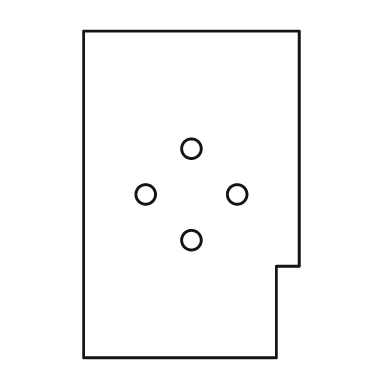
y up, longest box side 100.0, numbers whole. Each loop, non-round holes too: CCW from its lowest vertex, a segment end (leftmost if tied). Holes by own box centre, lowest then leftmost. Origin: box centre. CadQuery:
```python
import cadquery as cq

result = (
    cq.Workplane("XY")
    .moveTo(-33.0, -50.0)
    .lineTo(26.0, -50.0)
    .lineTo(26.0, -22.0)
    .lineTo(33.0, -22.0)
    .lineTo(33.0, 50.0)
    .lineTo(-33.0, 50.0)
    .close()
    .moveTo(0.0, -14.0)
    .circle(3.0)
    .moveTo(-14.0, 0.0)
    .circle(3.0)
    .moveTo(14.0, 0.0)
    .circle(3.0)
    .moveTo(0.0, 14.0)
    .circle(3.0)
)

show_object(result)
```